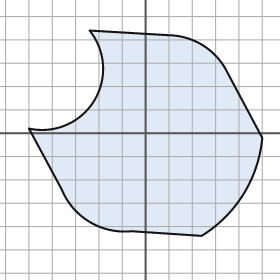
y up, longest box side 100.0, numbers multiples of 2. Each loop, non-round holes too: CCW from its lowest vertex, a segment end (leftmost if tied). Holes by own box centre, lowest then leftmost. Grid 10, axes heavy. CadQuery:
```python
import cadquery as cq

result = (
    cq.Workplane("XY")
    .moveTo(24.0, -44.0)
    .threePointArc((42.0, -26.0), (50.0, -2.0))
    .lineTo(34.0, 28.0)
    .threePointArc((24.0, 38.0), (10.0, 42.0))
    .lineTo(-24.0, 44.0)
    .threePointArc((-22.0, 14.0), (-50.0, 2.0))
    .lineTo(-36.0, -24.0)
    .threePointArc((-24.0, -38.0), (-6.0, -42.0))
    .close()
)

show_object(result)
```